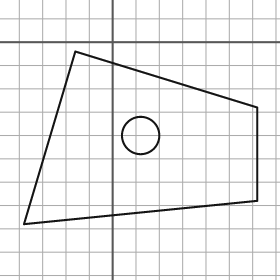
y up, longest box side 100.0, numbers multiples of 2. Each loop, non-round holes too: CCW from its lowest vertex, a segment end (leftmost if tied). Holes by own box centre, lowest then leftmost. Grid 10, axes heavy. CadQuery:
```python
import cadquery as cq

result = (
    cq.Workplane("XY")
    .moveTo(-38.0, -78.0)
    .lineTo(62.0, -68.0)
    .lineTo(62.0, -28.0)
    .lineTo(-16.0, -4.0)
    .close()
    .moveTo(12.0, -40.0)
    .circle(8.0)
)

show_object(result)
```